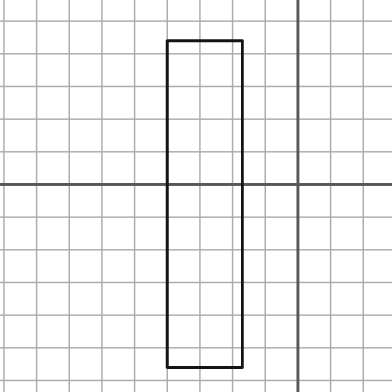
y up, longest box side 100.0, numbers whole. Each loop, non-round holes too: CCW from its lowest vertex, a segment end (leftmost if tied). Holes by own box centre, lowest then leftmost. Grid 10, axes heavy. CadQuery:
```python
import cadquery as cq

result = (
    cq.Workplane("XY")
    .moveTo(-40.0, -56.0)
    .lineTo(-17.0, -56.0)
    .lineTo(-17.0, 44.0)
    .lineTo(-40.0, 44.0)
    .close()
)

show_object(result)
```